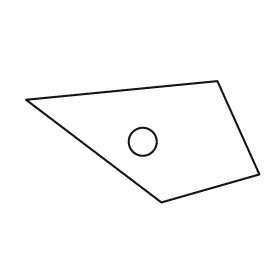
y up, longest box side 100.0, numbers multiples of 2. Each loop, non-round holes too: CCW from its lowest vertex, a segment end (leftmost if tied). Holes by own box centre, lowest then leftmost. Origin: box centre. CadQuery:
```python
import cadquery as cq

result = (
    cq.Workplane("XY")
    .moveTo(8.0, -26.0)
    .lineTo(50.0, -14.0)
    .lineTo(32.0, 26.0)
    .lineTo(-50.0, 18.0)
    .close()
    .moveTo(0.0, 0.0)
    .circle(6.0)
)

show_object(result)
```